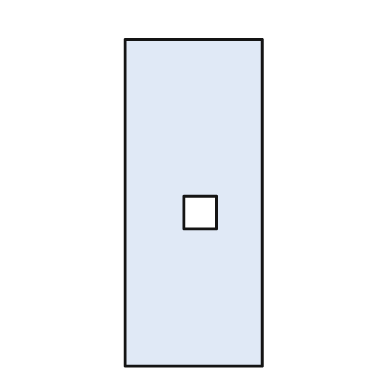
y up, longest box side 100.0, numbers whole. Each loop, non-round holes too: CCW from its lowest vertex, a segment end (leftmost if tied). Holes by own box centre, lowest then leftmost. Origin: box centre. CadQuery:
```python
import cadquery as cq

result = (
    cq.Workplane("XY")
    .moveTo(-21.0, -50.0)
    .lineTo(21.0, -50.0)
    .lineTo(21.0, 50.0)
    .lineTo(-21.0, 50.0)
    .close()
    .moveTo(-3.0, -8.0)
    .lineTo(7.0, -8.0)
    .lineTo(7.0, 2.0)
    .lineTo(-3.0, 2.0)
    .close()
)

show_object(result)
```